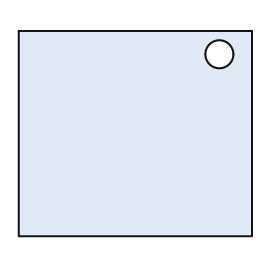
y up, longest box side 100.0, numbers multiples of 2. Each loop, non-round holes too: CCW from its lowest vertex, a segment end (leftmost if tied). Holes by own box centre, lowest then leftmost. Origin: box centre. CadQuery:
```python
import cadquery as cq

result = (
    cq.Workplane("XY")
    .moveTo(-50.0, -44.0)
    .lineTo(50.0, -44.0)
    .lineTo(50.0, 44.0)
    .lineTo(-50.0, 44.0)
    .close()
    .moveTo(36.0, 34.0)
    .circle(6.0)
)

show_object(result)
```